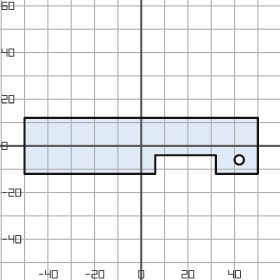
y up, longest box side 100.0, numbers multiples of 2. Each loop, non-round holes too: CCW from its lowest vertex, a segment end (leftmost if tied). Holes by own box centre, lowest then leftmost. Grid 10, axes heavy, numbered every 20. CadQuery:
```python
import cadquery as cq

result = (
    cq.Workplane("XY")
    .moveTo(-50.0, -12.0)
    .lineTo(6.0, -12.0)
    .lineTo(6.0, -4.0)
    .lineTo(32.0, -4.0)
    .lineTo(32.0, -12.0)
    .lineTo(50.0, -12.0)
    .lineTo(50.0, 12.0)
    .lineTo(-50.0, 12.0)
    .close()
    .moveTo(42.0, -6.0)
    .circle(2.0)
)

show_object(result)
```